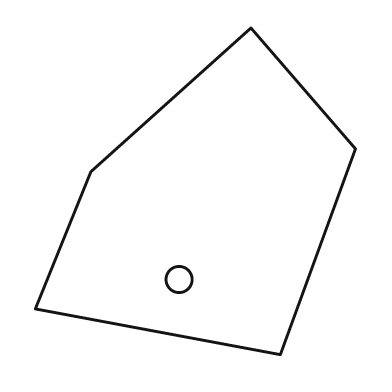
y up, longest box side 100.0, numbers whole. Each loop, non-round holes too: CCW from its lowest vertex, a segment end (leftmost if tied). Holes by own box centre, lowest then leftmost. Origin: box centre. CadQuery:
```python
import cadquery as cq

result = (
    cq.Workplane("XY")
    .moveTo(26.0, -50.0)
    .lineTo(49.0, 13.0)
    .lineTo(17.0, 50.0)
    .lineTo(-32.0, 6.0)
    .lineTo(-49.0, -36.0)
    .close()
    .moveTo(-5.0, -27.0)
    .circle(4.0)
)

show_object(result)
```